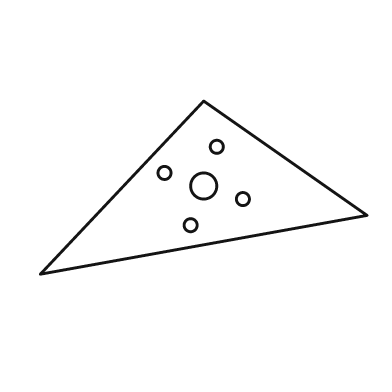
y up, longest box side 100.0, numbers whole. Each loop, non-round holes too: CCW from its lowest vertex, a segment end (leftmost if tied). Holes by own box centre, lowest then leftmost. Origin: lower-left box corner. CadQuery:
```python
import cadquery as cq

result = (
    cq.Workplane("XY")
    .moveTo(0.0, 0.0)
    .lineTo(100.0, 18.0)
    .lineTo(50.0, 53.0)
    .close()
    .moveTo(46.0, 15.0)
    .circle(2.0)
    .moveTo(62.0, 23.0)
    .circle(2.0)
    .moveTo(50.0, 27.0)
    .circle(4.0)
    .moveTo(38.0, 31.0)
    .circle(2.0)
    .moveTo(54.0, 39.0)
    .circle(2.0)
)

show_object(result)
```